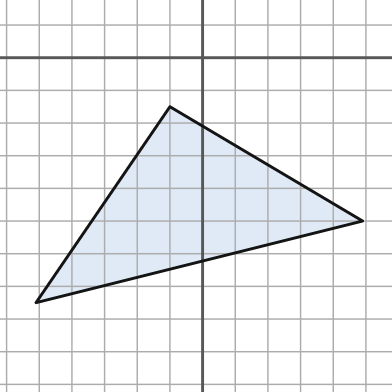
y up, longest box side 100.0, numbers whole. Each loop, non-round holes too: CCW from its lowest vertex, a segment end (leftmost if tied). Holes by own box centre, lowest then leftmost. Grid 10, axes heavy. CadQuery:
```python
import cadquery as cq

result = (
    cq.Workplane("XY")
    .moveTo(-51.0, -75.0)
    .lineTo(49.0, -50.0)
    .lineTo(-10.0, -15.0)
    .close()
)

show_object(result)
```